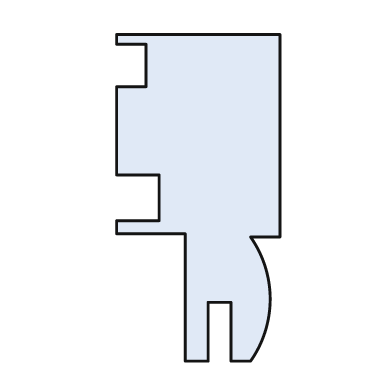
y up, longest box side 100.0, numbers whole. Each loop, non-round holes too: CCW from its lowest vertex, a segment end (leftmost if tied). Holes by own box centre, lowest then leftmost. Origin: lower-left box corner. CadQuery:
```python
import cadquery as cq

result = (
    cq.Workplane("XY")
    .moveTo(21.0, 0.0)
    .lineTo(28.0, 0.0)
    .lineTo(28.0, 18.0)
    .lineTo(35.0, 18.0)
    .lineTo(35.0, 0.0)
    .lineTo(41.0, 0.0)
    .threePointArc((47.0, 19.0), (41.0, 38.0))
    .lineTo(50.0, 38.0)
    .lineTo(50.0, 100.0)
    .lineTo(0.0, 100.0)
    .lineTo(0.0, 97.0)
    .lineTo(9.0, 97.0)
    .lineTo(9.0, 84.0)
    .lineTo(0.0, 84.0)
    .lineTo(0.0, 57.0)
    .lineTo(13.0, 57.0)
    .lineTo(13.0, 43.0)
    .lineTo(0.0, 43.0)
    .lineTo(0.0, 39.0)
    .lineTo(21.0, 39.0)
    .close()
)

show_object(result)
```